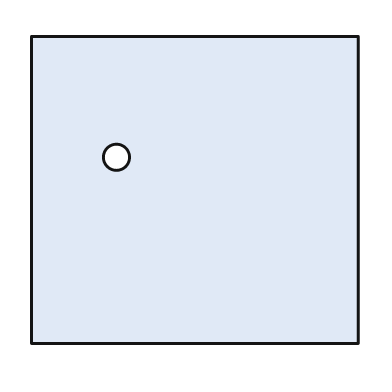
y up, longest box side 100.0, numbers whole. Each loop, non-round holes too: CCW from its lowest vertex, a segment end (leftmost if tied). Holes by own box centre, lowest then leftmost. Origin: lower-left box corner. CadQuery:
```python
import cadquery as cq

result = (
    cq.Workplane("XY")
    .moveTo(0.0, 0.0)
    .lineTo(100.0, 0.0)
    .lineTo(100.0, 94.0)
    .lineTo(0.0, 94.0)
    .close()
    .moveTo(26.0, 57.0)
    .circle(4.0)
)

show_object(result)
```